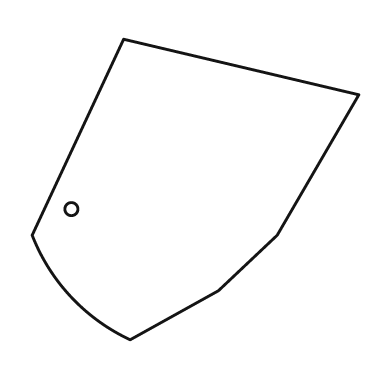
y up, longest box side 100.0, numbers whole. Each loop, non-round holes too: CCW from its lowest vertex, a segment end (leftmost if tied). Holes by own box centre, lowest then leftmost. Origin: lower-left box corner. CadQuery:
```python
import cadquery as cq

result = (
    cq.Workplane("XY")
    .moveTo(30.0, 0.0)
    .lineTo(57.0, 15.0)
    .lineTo(75.0, 32.0)
    .lineTo(100.0, 75.0)
    .lineTo(28.0, 92.0)
    .lineTo(0.0, 32.0)
    .threePointArc((12.0, 13.0), (30.0, 0.0))
    .close()
    .moveTo(12.0, 40.0)
    .circle(2.0)
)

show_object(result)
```